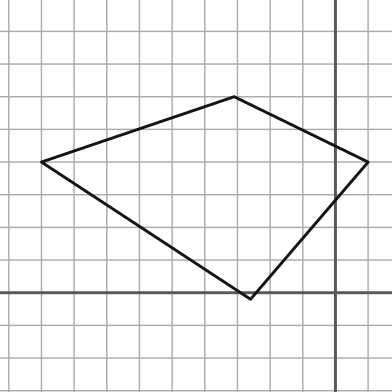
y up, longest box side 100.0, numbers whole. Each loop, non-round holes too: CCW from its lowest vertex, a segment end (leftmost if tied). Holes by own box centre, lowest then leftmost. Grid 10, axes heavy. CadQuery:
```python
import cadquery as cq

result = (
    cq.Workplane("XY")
    .moveTo(-26.0, -2.0)
    .lineTo(10.0, 40.0)
    .lineTo(-31.0, 60.0)
    .lineTo(-90.0, 40.0)
    .close()
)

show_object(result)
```